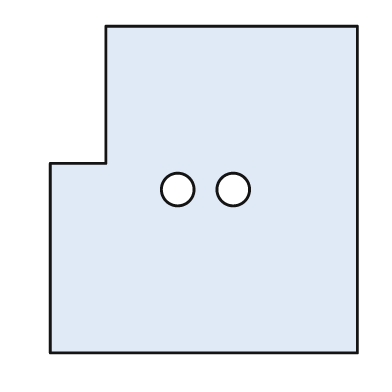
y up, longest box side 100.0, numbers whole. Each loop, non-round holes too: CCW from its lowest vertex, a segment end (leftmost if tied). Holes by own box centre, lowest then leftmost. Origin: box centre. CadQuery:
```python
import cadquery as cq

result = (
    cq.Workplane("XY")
    .moveTo(-47.0, -50.0)
    .lineTo(47.0, -50.0)
    .lineTo(47.0, 50.0)
    .lineTo(-30.0, 50.0)
    .lineTo(-30.0, 8.0)
    .lineTo(-47.0, 8.0)
    .close()
    .moveTo(-8.0, 0.0)
    .circle(5.0)
    .moveTo(9.0, 0.0)
    .circle(5.0)
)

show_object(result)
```